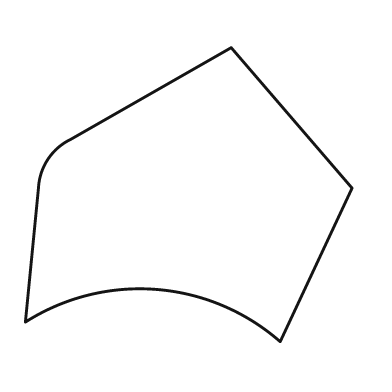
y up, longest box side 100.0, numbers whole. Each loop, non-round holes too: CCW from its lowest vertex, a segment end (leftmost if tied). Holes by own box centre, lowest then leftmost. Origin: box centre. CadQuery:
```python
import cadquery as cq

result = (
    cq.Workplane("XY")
    .moveTo(28.0, -45.0)
    .lineTo(50.0, 2.0)
    .lineTo(13.0, 45.0)
    .lineTo(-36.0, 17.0)
    .threePointArc((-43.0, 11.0), (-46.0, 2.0))
    .lineTo(-50.0, -39.0)
    .threePointArc((-10.0, -29.0), (28.0, -45.0))
    .close()
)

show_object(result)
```